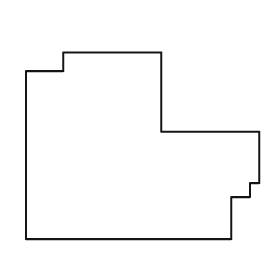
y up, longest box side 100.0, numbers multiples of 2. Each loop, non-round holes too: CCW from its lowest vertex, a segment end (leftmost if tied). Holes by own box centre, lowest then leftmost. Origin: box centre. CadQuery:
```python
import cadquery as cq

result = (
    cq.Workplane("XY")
    .moveTo(-50.0, -40.0)
    .lineTo(38.0, -40.0)
    .lineTo(38.0, -22.0)
    .lineTo(46.0, -22.0)
    .lineTo(46.0, -16.0)
    .lineTo(50.0, -16.0)
    .lineTo(50.0, 6.0)
    .lineTo(8.0, 6.0)
    .lineTo(8.0, 40.0)
    .lineTo(-34.0, 40.0)
    .lineTo(-34.0, 32.0)
    .lineTo(-50.0, 32.0)
    .close()
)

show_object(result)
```